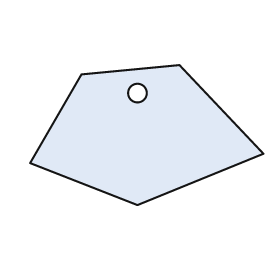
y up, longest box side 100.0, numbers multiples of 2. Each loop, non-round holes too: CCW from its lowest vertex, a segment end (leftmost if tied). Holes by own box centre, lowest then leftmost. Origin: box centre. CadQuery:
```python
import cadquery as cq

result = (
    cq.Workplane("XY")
    .moveTo(-4.0, -30.0)
    .lineTo(50.0, -8.0)
    .lineTo(14.0, 30.0)
    .lineTo(-28.0, 26.0)
    .lineTo(-50.0, -12.0)
    .close()
    .moveTo(-4.0, 18.0)
    .circle(4.0)
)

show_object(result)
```